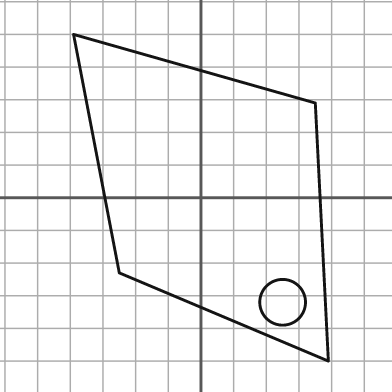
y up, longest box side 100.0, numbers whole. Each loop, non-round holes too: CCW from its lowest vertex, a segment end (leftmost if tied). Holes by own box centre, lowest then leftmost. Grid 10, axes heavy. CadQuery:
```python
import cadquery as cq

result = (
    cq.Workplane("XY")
    .moveTo(39.0, -50.0)
    .lineTo(35.0, 29.0)
    .lineTo(-39.0, 50.0)
    .lineTo(-25.0, -23.0)
    .close()
    .moveTo(25.0, -32.0)
    .circle(7.0)
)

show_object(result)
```